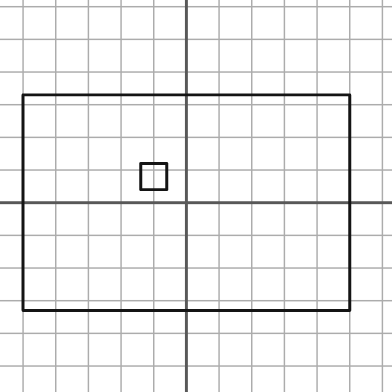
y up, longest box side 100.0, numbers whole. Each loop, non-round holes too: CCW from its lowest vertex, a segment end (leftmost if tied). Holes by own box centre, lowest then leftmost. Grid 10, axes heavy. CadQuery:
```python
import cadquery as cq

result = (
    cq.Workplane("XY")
    .moveTo(-50.0, -33.0)
    .lineTo(50.0, -33.0)
    .lineTo(50.0, 33.0)
    .lineTo(-50.0, 33.0)
    .close()
    .moveTo(-14.0, 4.0)
    .lineTo(-6.0, 4.0)
    .lineTo(-6.0, 12.0)
    .lineTo(-14.0, 12.0)
    .close()
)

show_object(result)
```